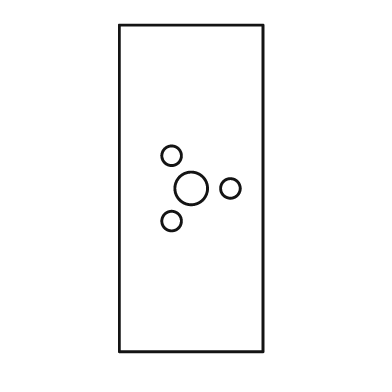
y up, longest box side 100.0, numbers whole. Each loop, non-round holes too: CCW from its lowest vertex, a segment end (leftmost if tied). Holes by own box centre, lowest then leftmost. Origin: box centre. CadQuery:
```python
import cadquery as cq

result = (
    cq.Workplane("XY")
    .moveTo(-22.0, -50.0)
    .lineTo(22.0, -50.0)
    .lineTo(22.0, 50.0)
    .lineTo(-22.0, 50.0)
    .close()
    .moveTo(-6.0, -10.0)
    .circle(3.0)
    .moveTo(0.0, 0.0)
    .circle(5.0)
    .moveTo(12.0, 0.0)
    .circle(3.0)
    .moveTo(-6.0, 10.0)
    .circle(3.0)
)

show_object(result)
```